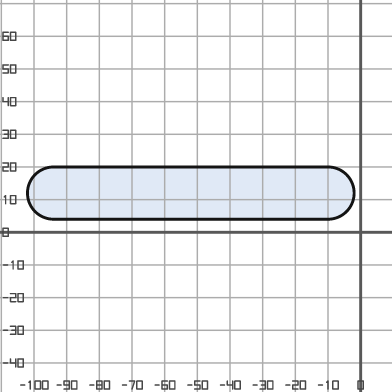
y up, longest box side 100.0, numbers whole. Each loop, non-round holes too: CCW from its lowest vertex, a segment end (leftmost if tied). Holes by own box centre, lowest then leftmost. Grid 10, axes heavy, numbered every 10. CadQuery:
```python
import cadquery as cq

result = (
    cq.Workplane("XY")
    .moveTo(-94.0, 4.0)
    .lineTo(-10.0, 4.0)
    .threePointArc((-2.0, 12.0), (-10.0, 20.0))
    .lineTo(-94.0, 20.0)
    .threePointArc((-102.0, 12.0), (-94.0, 4.0))
    .close()
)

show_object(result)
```